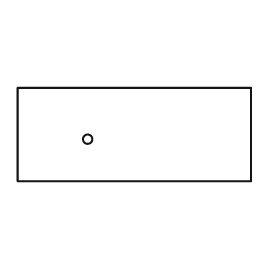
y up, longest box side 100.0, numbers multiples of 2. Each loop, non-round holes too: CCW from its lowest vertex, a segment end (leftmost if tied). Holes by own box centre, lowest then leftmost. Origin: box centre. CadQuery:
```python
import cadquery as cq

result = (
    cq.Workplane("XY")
    .moveTo(-50.0, -20.0)
    .lineTo(50.0, -20.0)
    .lineTo(50.0, 20.0)
    .lineTo(-50.0, 20.0)
    .close()
    .moveTo(-20.0, -2.0)
    .circle(2.0)
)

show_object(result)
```